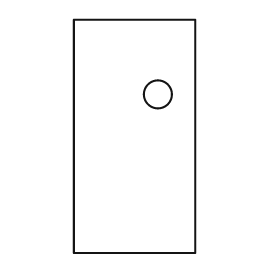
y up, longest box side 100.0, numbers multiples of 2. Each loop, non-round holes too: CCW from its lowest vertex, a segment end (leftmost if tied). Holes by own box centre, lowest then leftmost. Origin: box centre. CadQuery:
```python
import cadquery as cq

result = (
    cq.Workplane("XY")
    .moveTo(-26.0, -50.0)
    .lineTo(26.0, -50.0)
    .lineTo(26.0, 50.0)
    .lineTo(-26.0, 50.0)
    .close()
    .moveTo(10.0, 18.0)
    .circle(6.0)
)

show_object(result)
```